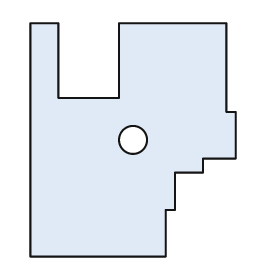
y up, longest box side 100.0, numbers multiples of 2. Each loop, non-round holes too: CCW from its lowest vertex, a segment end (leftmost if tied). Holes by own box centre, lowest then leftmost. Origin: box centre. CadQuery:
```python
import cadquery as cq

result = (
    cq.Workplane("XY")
    .moveTo(-44.0, -50.0)
    .lineTo(14.0, -50.0)
    .lineTo(14.0, -30.0)
    .lineTo(18.0, -30.0)
    .lineTo(18.0, -14.0)
    .lineTo(30.0, -14.0)
    .lineTo(30.0, -8.0)
    .lineTo(44.0, -8.0)
    .lineTo(44.0, 12.0)
    .lineTo(40.0, 12.0)
    .lineTo(40.0, 50.0)
    .lineTo(-6.0, 50.0)
    .lineTo(-6.0, 18.0)
    .lineTo(-32.0, 18.0)
    .lineTo(-32.0, 50.0)
    .lineTo(-44.0, 50.0)
    .close()
    .moveTo(0.0, 0.0)
    .circle(6.0)
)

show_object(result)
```